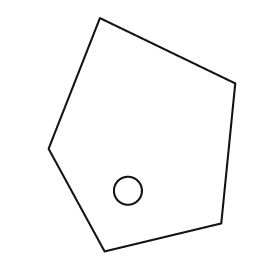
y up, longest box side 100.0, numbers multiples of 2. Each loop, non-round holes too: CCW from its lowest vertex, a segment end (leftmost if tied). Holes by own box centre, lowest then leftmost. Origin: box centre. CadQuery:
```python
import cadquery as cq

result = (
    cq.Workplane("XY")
    .moveTo(-16.0, -50.0)
    .lineTo(34.0, -38.0)
    .lineTo(40.0, 22.0)
    .lineTo(-18.0, 50.0)
    .lineTo(-40.0, -6.0)
    .close()
    .moveTo(-6.0, -24.0)
    .circle(6.0)
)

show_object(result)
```